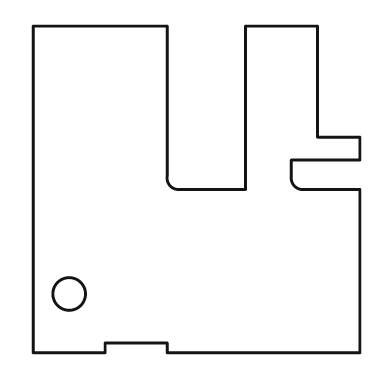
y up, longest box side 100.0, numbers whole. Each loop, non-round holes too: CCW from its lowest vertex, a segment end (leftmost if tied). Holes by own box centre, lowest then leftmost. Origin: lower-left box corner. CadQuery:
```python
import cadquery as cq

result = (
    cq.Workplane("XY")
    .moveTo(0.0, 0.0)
    .lineTo(22.0, 0.0)
    .lineTo(22.0, 3.0)
    .lineTo(41.0, 3.0)
    .lineTo(41.0, 0.0)
    .lineTo(100.0, 0.0)
    .lineTo(100.0, 50.0)
    .lineTo(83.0, 50.0)
    .threePointArc((80.0, 51.0), (79.0, 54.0))
    .lineTo(79.0, 59.0)
    .lineTo(100.0, 59.0)
    .lineTo(100.0, 66.0)
    .lineTo(87.0, 66.0)
    .lineTo(87.0, 100.0)
    .lineTo(65.0, 100.0)
    .lineTo(65.0, 50.0)
    .lineTo(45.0, 50.0)
    .threePointArc((42.0, 51.0), (41.0, 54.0))
    .lineTo(41.0, 100.0)
    .lineTo(0.0, 100.0)
    .close()
    .moveTo(11.0, 18.0)
    .circle(5.0)
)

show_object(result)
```